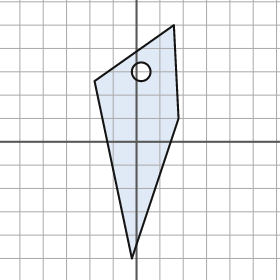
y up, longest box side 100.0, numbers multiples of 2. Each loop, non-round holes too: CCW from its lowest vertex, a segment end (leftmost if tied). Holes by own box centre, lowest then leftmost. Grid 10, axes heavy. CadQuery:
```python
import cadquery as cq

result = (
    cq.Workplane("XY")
    .moveTo(-2.0, -50.0)
    .lineTo(18.0, 10.0)
    .lineTo(16.0, 50.0)
    .lineTo(-18.0, 26.0)
    .close()
    .moveTo(2.0, 30.0)
    .circle(4.0)
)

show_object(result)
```